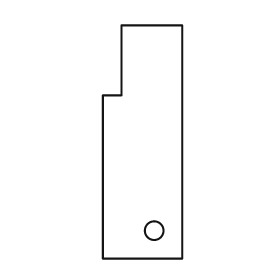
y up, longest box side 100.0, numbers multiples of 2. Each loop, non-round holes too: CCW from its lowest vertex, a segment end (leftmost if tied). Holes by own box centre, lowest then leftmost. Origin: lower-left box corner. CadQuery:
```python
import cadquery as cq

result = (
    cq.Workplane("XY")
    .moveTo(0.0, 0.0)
    .lineTo(34.0, 0.0)
    .lineTo(34.0, 100.0)
    .lineTo(8.0, 100.0)
    .lineTo(8.0, 70.0)
    .lineTo(0.0, 70.0)
    .close()
    .moveTo(22.0, 12.0)
    .circle(4.0)
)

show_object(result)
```